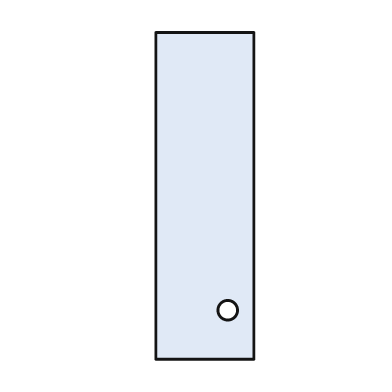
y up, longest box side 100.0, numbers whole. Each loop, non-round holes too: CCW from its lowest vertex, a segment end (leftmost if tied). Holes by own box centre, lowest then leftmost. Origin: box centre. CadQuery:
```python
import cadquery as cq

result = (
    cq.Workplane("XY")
    .moveTo(-15.0, -50.0)
    .lineTo(15.0, -50.0)
    .lineTo(15.0, 50.0)
    .lineTo(-15.0, 50.0)
    .close()
    .moveTo(7.0, -35.0)
    .circle(3.0)
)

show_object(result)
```